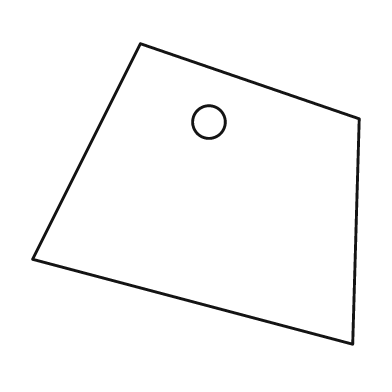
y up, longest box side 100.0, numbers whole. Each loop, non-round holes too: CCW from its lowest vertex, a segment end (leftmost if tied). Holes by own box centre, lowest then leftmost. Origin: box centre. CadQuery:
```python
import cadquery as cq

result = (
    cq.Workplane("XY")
    .moveTo(48.0, -46.0)
    .lineTo(50.0, 23.0)
    .lineTo(-17.0, 46.0)
    .lineTo(-50.0, -20.0)
    .close()
    .moveTo(4.0, 22.0)
    .circle(5.0)
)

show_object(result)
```